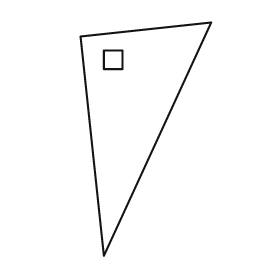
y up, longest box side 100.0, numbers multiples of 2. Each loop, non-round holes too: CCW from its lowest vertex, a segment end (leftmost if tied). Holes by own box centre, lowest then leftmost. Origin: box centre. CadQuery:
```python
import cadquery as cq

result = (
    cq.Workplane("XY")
    .moveTo(-18.0, -50.0)
    .lineTo(28.0, 50.0)
    .lineTo(-28.0, 44.0)
    .close()
    .moveTo(-18.0, 30.0)
    .lineTo(-10.0, 30.0)
    .lineTo(-10.0, 38.0)
    .lineTo(-18.0, 38.0)
    .close()
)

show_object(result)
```